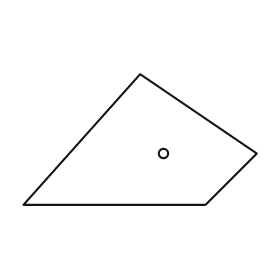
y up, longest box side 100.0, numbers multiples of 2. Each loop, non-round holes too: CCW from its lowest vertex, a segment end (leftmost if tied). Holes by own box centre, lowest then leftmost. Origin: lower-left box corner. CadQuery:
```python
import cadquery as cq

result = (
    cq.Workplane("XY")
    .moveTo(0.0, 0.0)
    .lineTo(78.0, 0.0)
    .lineTo(100.0, 22.0)
    .lineTo(50.0, 56.0)
    .close()
    .moveTo(60.0, 22.0)
    .circle(2.0)
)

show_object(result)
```